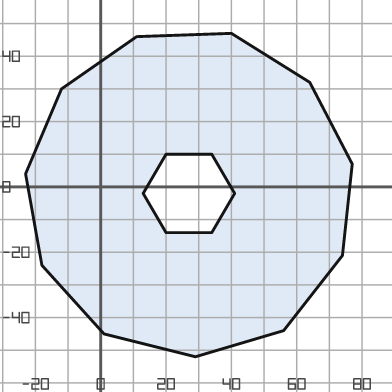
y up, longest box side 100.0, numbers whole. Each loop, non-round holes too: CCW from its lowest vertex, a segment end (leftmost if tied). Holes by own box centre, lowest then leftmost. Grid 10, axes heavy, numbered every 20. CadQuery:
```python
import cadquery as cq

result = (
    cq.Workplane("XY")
    .moveTo(29.0, -52.0)
    .lineTo(56.0, -44.0)
    .lineTo(74.0, -21.0)
    .lineTo(77.0, 7.0)
    .lineTo(64.0, 32.0)
    .lineTo(40.0, 47.0)
    .lineTo(11.0, 46.0)
    .lineTo(-12.0, 30.0)
    .lineTo(-23.0, 4.0)
    .lineTo(-18.0, -24.0)
    .lineTo(1.0, -45.0)
    .close()
    .moveTo(20.0, -14.0)
    .lineTo(34.0, -14.0)
    .lineTo(41.0, -2.0)
    .lineTo(34.0, 10.0)
    .lineTo(20.0, 10.0)
    .lineTo(13.0, -2.0)
    .close()
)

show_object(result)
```